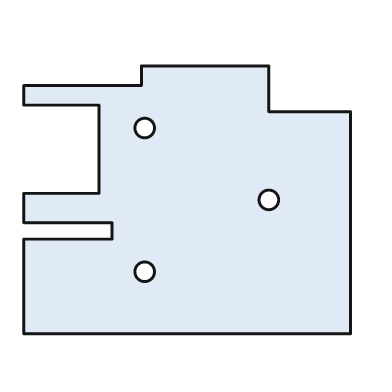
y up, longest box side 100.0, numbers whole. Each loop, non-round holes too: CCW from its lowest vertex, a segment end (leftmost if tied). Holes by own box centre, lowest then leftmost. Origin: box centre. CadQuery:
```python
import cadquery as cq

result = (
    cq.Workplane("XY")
    .moveTo(-50.0, -41.0)
    .lineTo(50.0, -41.0)
    .lineTo(50.0, 27.0)
    .lineTo(25.0, 27.0)
    .lineTo(25.0, 41.0)
    .lineTo(-14.0, 41.0)
    .lineTo(-14.0, 35.0)
    .lineTo(-50.0, 35.0)
    .lineTo(-50.0, 29.0)
    .lineTo(-27.0, 29.0)
    .lineTo(-27.0, 2.0)
    .lineTo(-50.0, 2.0)
    .lineTo(-50.0, -7.0)
    .lineTo(-23.0, -7.0)
    .lineTo(-23.0, -12.0)
    .lineTo(-50.0, -12.0)
    .close()
    .moveTo(-13.0, -22.0)
    .circle(3.0)
    .moveTo(25.0, 0.0)
    .circle(3.0)
    .moveTo(-13.0, 22.0)
    .circle(3.0)
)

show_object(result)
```